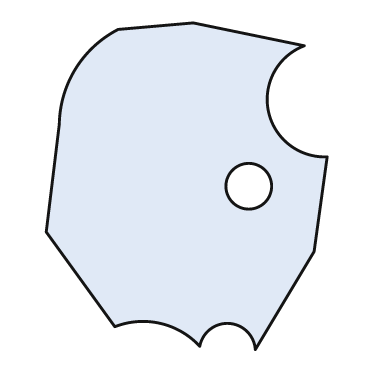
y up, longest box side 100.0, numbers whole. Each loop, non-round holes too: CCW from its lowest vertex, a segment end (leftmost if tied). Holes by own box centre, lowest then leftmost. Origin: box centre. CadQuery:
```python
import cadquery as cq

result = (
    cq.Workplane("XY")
    .moveTo(21.0, -50.0)
    .lineTo(39.0, -20.0)
    .lineTo(43.0, 9.0)
    .threePointArc((25.0, 23.0), (36.0, 43.0))
    .lineTo(2.0, 50.0)
    .lineTo(-21.0, 48.0)
    .threePointArc((-34.0, 36.0), (-39.0, 19.0))
    .lineTo(-43.0, -14.0)
    .lineTo(-22.0, -43.0)
    .threePointArc((-8.0, -42.0), (4.0, -49.0))
    .threePointArc((13.0, -42.0), (21.0, -50.0))
    .close()
    .moveTo(19.0, 0.0)
    .circle(7.0)
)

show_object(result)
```